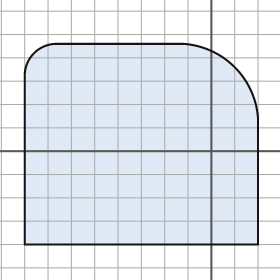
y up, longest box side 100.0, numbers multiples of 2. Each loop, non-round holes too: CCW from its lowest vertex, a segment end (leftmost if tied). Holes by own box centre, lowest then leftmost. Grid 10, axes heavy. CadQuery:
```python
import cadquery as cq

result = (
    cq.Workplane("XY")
    .moveTo(-80.0, -40.0)
    .lineTo(20.0, -40.0)
    .lineTo(20.0, 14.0)
    .threePointArc((10.0, 36.0), (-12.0, 46.0))
    .lineTo(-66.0, 46.0)
    .threePointArc((-76.0, 42.0), (-80.0, 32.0))
    .close()
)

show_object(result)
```